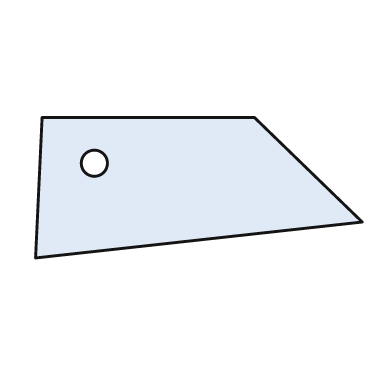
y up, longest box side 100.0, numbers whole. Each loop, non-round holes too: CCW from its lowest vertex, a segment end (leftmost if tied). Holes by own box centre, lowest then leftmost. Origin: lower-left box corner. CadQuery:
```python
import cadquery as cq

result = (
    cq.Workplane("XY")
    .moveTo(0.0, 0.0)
    .lineTo(100.0, 11.0)
    .lineTo(67.0, 43.0)
    .lineTo(2.0, 43.0)
    .close()
    .moveTo(18.0, 29.0)
    .circle(4.0)
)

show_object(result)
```